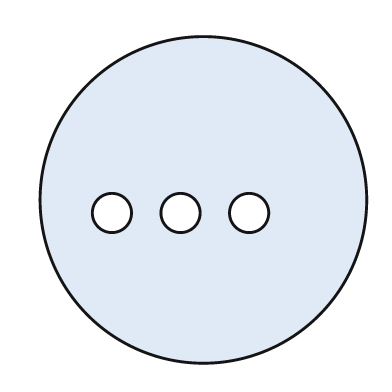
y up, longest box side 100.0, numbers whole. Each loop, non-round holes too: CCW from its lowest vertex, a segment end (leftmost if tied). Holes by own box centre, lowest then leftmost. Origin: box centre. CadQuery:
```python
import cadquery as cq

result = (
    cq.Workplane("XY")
    .moveTo(0.0, 0.0)
    .circle(50.0)
    .moveTo(-28.0, -4.0)
    .circle(6.0)
    .moveTo(-7.0, -4.0)
    .circle(6.0)
    .moveTo(14.0, -4.0)
    .circle(6.0)
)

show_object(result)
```